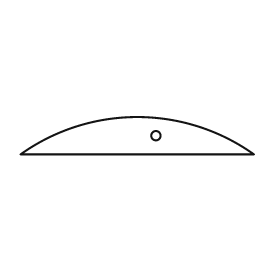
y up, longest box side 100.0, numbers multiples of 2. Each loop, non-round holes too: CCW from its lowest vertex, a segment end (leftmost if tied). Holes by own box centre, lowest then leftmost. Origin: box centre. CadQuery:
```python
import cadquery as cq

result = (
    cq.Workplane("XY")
    .moveTo(-50.0, -8.0)
    .lineTo(50.0, -8.0)
    .threePointArc((0.0, 8.0), (-50.0, -8.0))
    .close()
    .moveTo(8.0, 0.0)
    .circle(2.0)
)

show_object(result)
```